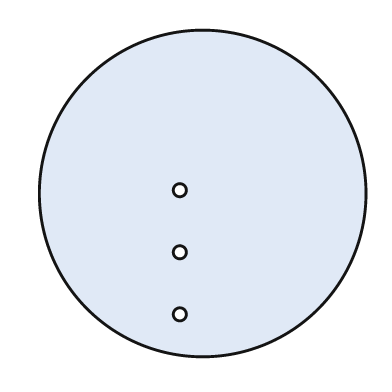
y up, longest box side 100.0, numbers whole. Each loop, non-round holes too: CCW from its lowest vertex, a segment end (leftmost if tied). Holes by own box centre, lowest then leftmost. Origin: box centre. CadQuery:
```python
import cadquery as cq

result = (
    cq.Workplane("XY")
    .moveTo(0.0, 0.0)
    .circle(50.0)
    .moveTo(-7.0, -37.0)
    .circle(2.0)
    .moveTo(-7.0, -18.0)
    .circle(2.0)
    .moveTo(-7.0, 1.0)
    .circle(2.0)
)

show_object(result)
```